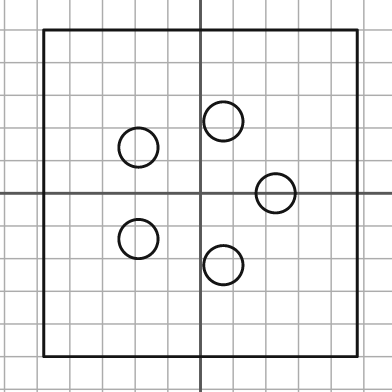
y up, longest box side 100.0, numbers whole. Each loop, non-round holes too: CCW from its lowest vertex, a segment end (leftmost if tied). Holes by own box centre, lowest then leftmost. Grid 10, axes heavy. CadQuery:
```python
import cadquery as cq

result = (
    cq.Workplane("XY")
    .moveTo(-48.0, -50.0)
    .lineTo(48.0, -50.0)
    .lineTo(48.0, 50.0)
    .lineTo(-48.0, 50.0)
    .close()
    .moveTo(7.0, -22.0)
    .circle(6.0)
    .moveTo(-19.0, -14.0)
    .circle(6.0)
    .moveTo(23.0, 0.0)
    .circle(6.0)
    .moveTo(-19.0, 14.0)
    .circle(6.0)
    .moveTo(7.0, 22.0)
    .circle(6.0)
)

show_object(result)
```